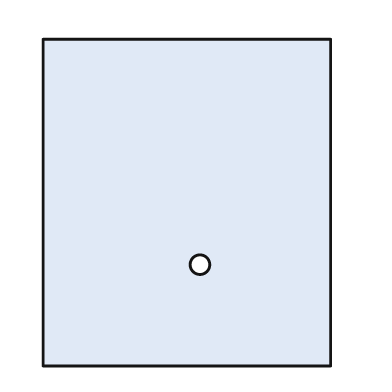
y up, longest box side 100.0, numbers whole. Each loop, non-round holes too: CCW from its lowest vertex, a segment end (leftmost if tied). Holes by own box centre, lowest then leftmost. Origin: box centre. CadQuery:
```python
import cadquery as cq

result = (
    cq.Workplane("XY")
    .moveTo(-44.0, -50.0)
    .lineTo(44.0, -50.0)
    .lineTo(44.0, 50.0)
    .lineTo(-44.0, 50.0)
    .close()
    .moveTo(4.0, -19.0)
    .circle(3.0)
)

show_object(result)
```